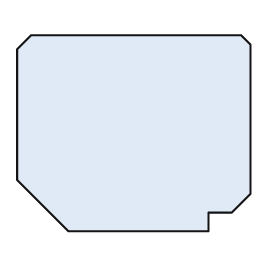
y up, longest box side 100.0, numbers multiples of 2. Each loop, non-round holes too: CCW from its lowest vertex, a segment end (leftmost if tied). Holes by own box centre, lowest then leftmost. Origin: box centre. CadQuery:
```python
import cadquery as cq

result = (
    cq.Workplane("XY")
    .moveTo(-28.0, -42.0)
    .lineTo(32.0, -42.0)
    .lineTo(32.0, -34.0)
    .lineTo(42.0, -34.0)
    .lineTo(50.0, -26.0)
    .lineTo(50.0, 38.0)
    .lineTo(46.0, 42.0)
    .lineTo(-44.0, 42.0)
    .lineTo(-50.0, 36.0)
    .lineTo(-50.0, -20.0)
    .close()
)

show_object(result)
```